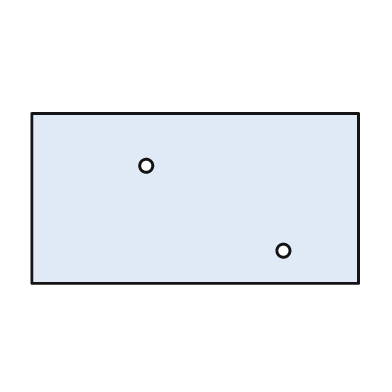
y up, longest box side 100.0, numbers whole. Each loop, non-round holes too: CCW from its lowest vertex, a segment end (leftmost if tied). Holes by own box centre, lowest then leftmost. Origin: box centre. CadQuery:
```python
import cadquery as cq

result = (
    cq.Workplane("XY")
    .moveTo(-50.0, -26.0)
    .lineTo(50.0, -26.0)
    .lineTo(50.0, 26.0)
    .lineTo(-50.0, 26.0)
    .close()
    .moveTo(27.0, -16.0)
    .circle(2.0)
    .moveTo(-15.0, 10.0)
    .circle(2.0)
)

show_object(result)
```